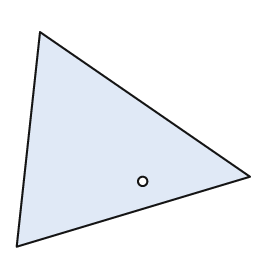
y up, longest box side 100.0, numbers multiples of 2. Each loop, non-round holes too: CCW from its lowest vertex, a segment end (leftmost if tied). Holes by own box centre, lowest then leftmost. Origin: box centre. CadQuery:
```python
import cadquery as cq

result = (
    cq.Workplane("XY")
    .moveTo(-50.0, -46.0)
    .lineTo(50.0, -16.0)
    .lineTo(-40.0, 46.0)
    .close()
    .moveTo(4.0, -18.0)
    .circle(2.0)
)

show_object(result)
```